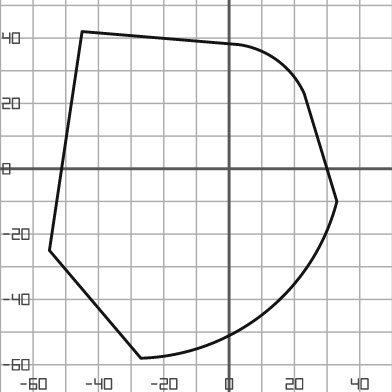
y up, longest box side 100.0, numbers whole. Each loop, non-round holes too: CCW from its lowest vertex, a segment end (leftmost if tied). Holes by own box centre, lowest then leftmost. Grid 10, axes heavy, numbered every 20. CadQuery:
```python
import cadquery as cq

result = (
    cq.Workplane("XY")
    .moveTo(-27.0, -58.0)
    .threePointArc((11.0, -44.0), (33.0, -10.0))
    .lineTo(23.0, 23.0)
    .threePointArc((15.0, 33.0), (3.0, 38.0))
    .lineTo(-45.0, 42.0)
    .lineTo(-55.0, -25.0)
    .close()
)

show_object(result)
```